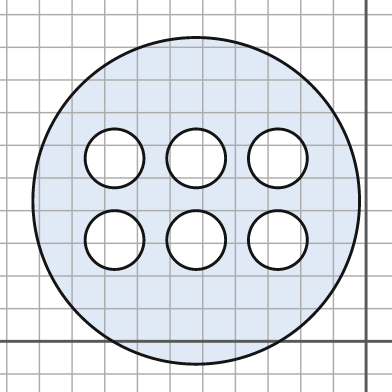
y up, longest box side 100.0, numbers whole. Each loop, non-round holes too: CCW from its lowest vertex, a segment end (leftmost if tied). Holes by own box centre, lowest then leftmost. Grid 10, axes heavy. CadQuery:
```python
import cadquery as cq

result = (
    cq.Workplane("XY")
    .moveTo(-52.0, 43.0)
    .circle(50.0)
    .moveTo(-77.0, 31.0)
    .circle(9.0)
    .moveTo(-52.0, 31.0)
    .circle(9.0)
    .moveTo(-27.0, 31.0)
    .circle(9.0)
    .moveTo(-77.0, 56.0)
    .circle(9.0)
    .moveTo(-52.0, 56.0)
    .circle(9.0)
    .moveTo(-27.0, 56.0)
    .circle(9.0)
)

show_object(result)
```